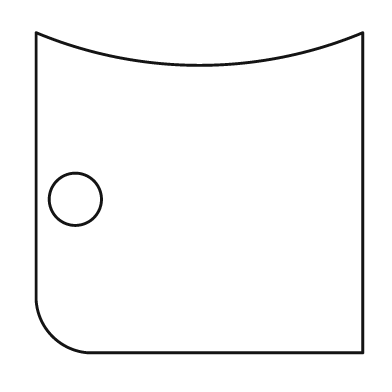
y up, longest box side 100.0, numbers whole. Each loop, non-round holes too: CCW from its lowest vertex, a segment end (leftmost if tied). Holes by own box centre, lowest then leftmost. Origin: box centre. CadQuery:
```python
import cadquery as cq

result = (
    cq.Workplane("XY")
    .moveTo(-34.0, -49.0)
    .lineTo(50.0, -49.0)
    .lineTo(50.0, 49.0)
    .threePointArc((0.0, 39.0), (-50.0, 49.0))
    .lineTo(-50.0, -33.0)
    .threePointArc((-45.0, -44.0), (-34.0, -49.0))
    .close()
    .moveTo(-38.0, -2.0)
    .circle(8.0)
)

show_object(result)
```